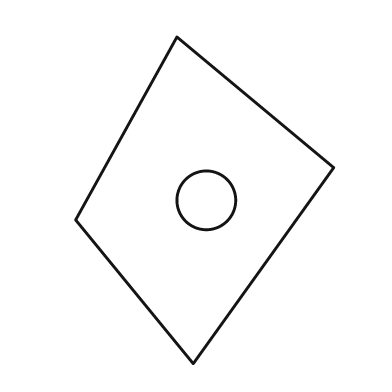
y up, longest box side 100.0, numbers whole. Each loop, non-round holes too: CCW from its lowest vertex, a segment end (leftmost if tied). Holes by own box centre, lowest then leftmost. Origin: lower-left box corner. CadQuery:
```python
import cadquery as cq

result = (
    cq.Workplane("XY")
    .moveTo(36.0, 0.0)
    .lineTo(79.0, 60.0)
    .lineTo(31.0, 100.0)
    .lineTo(0.0, 44.0)
    .close()
    .moveTo(40.0, 50.0)
    .circle(9.0)
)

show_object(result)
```